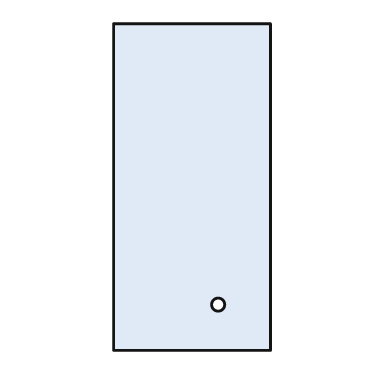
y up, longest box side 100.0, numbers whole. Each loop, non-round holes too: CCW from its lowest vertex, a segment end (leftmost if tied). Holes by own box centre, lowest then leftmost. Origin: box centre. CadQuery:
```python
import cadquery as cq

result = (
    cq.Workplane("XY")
    .moveTo(-24.0, -50.0)
    .lineTo(24.0, -50.0)
    .lineTo(24.0, 50.0)
    .lineTo(-24.0, 50.0)
    .close()
    .moveTo(8.0, -36.0)
    .circle(2.0)
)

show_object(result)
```